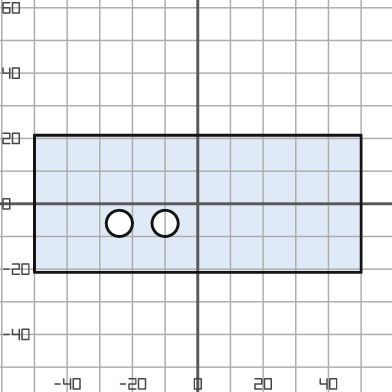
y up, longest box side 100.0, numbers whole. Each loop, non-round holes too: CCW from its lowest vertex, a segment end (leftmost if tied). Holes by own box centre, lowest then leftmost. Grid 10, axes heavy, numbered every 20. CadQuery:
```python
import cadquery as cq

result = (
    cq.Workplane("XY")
    .moveTo(-50.0, -21.0)
    .lineTo(50.0, -21.0)
    .lineTo(50.0, 21.0)
    .lineTo(-50.0, 21.0)
    .close()
    .moveTo(-24.0, -6.0)
    .circle(4.0)
    .moveTo(-10.0, -6.0)
    .circle(4.0)
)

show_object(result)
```